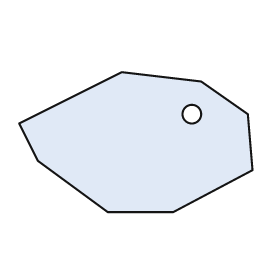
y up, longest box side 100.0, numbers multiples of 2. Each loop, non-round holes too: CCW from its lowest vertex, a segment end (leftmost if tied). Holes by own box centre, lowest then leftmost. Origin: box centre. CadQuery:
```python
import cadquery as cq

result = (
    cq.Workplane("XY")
    .moveTo(-12.0, -30.0)
    .lineTo(16.0, -30.0)
    .lineTo(50.0, -12.0)
    .lineTo(48.0, 12.0)
    .lineTo(28.0, 26.0)
    .lineTo(-6.0, 30.0)
    .lineTo(-50.0, 8.0)
    .lineTo(-42.0, -8.0)
    .close()
    .moveTo(24.0, 12.0)
    .circle(4.0)
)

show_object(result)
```